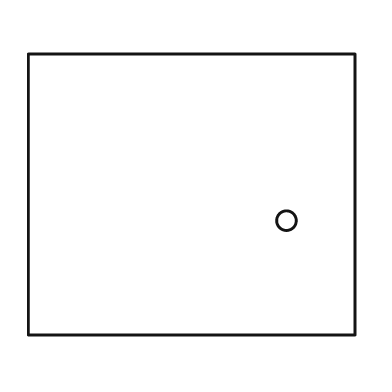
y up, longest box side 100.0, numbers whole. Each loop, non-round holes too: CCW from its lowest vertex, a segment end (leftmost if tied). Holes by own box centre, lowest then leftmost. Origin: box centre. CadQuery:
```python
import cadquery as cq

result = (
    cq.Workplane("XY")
    .moveTo(-50.0, -43.0)
    .lineTo(50.0, -43.0)
    .lineTo(50.0, 43.0)
    .lineTo(-50.0, 43.0)
    .close()
    .moveTo(29.0, -8.0)
    .circle(3.0)
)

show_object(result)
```